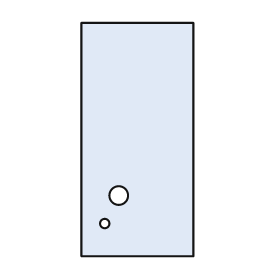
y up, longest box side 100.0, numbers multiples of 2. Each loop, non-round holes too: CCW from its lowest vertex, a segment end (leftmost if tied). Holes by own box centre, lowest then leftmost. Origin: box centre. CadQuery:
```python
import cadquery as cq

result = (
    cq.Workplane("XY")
    .moveTo(-24.0, -50.0)
    .lineTo(24.0, -50.0)
    .lineTo(24.0, 50.0)
    .lineTo(-24.0, 50.0)
    .close()
    .moveTo(-14.0, -36.0)
    .circle(2.0)
    .moveTo(-8.0, -24.0)
    .circle(4.0)
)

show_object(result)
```